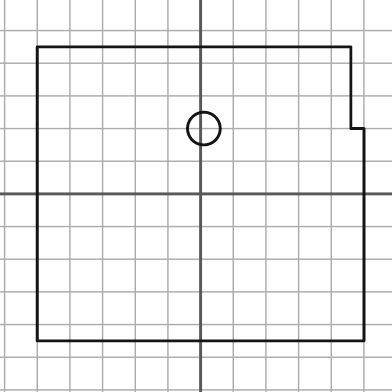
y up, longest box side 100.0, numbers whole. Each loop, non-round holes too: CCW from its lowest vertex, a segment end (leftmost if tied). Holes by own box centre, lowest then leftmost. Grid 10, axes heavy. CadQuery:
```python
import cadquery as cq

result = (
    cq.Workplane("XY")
    .moveTo(-50.0, -45.0)
    .lineTo(50.0, -45.0)
    .lineTo(50.0, 20.0)
    .lineTo(46.0, 20.0)
    .lineTo(46.0, 45.0)
    .lineTo(-50.0, 45.0)
    .close()
    .moveTo(1.0, 20.0)
    .circle(5.0)
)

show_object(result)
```